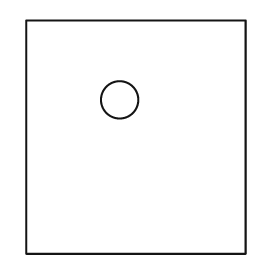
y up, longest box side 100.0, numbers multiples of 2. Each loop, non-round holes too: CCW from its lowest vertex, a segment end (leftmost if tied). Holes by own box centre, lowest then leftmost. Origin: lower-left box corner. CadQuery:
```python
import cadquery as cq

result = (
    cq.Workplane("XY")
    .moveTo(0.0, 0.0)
    .lineTo(94.0, 0.0)
    .lineTo(94.0, 100.0)
    .lineTo(0.0, 100.0)
    .close()
    .moveTo(40.0, 66.0)
    .circle(8.0)
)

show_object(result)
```